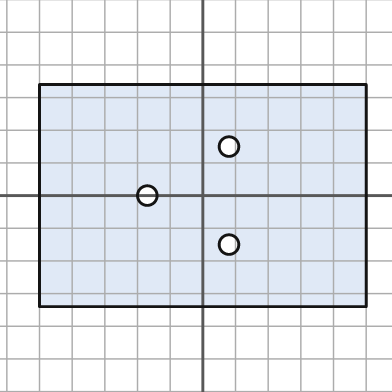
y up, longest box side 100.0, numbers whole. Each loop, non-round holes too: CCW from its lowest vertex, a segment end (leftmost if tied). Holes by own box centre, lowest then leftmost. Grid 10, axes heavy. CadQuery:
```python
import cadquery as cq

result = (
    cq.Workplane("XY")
    .moveTo(-50.0, -34.0)
    .lineTo(50.0, -34.0)
    .lineTo(50.0, 34.0)
    .lineTo(-50.0, 34.0)
    .close()
    .moveTo(8.0, -15.0)
    .circle(3.0)
    .moveTo(-17.0, 0.0)
    .circle(3.0)
    .moveTo(8.0, 15.0)
    .circle(3.0)
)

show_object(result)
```